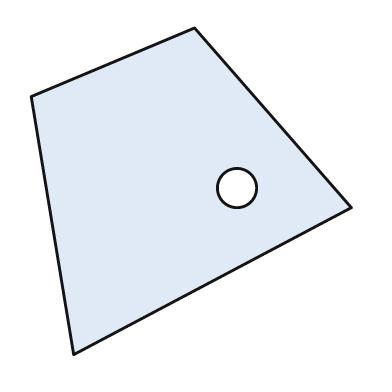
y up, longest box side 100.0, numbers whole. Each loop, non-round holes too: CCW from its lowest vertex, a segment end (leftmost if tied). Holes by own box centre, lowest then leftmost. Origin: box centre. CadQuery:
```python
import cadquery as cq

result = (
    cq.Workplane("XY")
    .moveTo(-36.0, -50.0)
    .lineTo(49.0, -5.0)
    .lineTo(1.0, 50.0)
    .lineTo(-49.0, 29.0)
    .close()
    .moveTo(14.0, 1.0)
    .circle(6.0)
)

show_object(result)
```